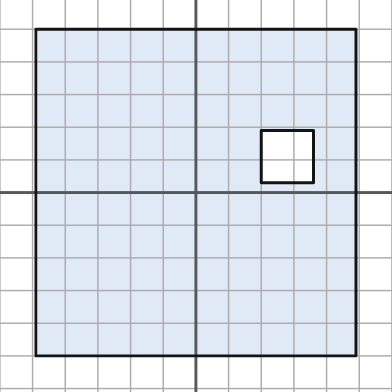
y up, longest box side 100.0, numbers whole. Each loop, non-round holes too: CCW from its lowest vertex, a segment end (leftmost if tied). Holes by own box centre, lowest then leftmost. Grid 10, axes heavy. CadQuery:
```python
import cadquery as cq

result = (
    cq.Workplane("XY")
    .moveTo(-49.0, -50.0)
    .lineTo(49.0, -50.0)
    .lineTo(49.0, 50.0)
    .lineTo(-49.0, 50.0)
    .close()
    .moveTo(20.0, 3.0)
    .lineTo(36.0, 3.0)
    .lineTo(36.0, 19.0)
    .lineTo(20.0, 19.0)
    .close()
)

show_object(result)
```